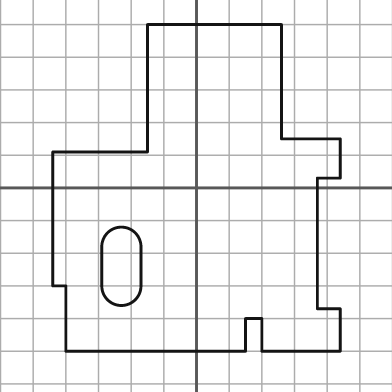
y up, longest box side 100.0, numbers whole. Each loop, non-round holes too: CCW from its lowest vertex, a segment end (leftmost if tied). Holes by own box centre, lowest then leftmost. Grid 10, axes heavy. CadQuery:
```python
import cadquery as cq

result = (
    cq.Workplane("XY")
    .moveTo(-40.0, -50.0)
    .lineTo(15.0, -50.0)
    .lineTo(15.0, -40.0)
    .lineTo(20.0, -40.0)
    .lineTo(20.0, -50.0)
    .lineTo(44.0, -50.0)
    .lineTo(44.0, -37.0)
    .lineTo(37.0, -37.0)
    .lineTo(37.0, 3.0)
    .lineTo(44.0, 3.0)
    .lineTo(44.0, 15.0)
    .lineTo(26.0, 15.0)
    .lineTo(26.0, 50.0)
    .lineTo(-15.0, 50.0)
    .lineTo(-15.0, 11.0)
    .lineTo(-44.0, 11.0)
    .lineTo(-44.0, -30.0)
    .lineTo(-40.0, -30.0)
    .close()
    .moveTo(-29.0, -30.0)
    .threePointArc((-23.0, -36.0), (-17.0, -30.0))
    .lineTo(-17.0, -18.0)
    .threePointArc((-23.0, -12.0), (-29.0, -18.0))
    .close()
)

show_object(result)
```